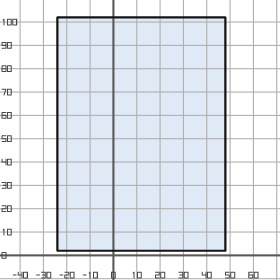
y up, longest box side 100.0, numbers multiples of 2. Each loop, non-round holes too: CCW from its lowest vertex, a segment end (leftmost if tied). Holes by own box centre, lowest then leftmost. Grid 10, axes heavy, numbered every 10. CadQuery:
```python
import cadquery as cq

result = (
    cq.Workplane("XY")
    .moveTo(-24.0, 2.0)
    .lineTo(48.0, 2.0)
    .lineTo(48.0, 102.0)
    .lineTo(-24.0, 102.0)
    .close()
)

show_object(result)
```